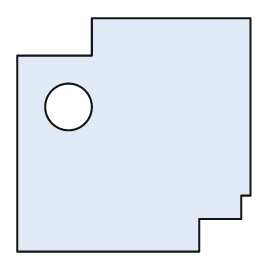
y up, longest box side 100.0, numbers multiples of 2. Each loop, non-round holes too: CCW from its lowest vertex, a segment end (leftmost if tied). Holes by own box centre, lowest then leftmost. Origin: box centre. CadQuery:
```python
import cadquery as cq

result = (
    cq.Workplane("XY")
    .moveTo(-50.0, -50.0)
    .lineTo(28.0, -50.0)
    .lineTo(28.0, -36.0)
    .lineTo(46.0, -36.0)
    .lineTo(46.0, -26.0)
    .lineTo(50.0, -26.0)
    .lineTo(50.0, 50.0)
    .lineTo(-18.0, 50.0)
    .lineTo(-18.0, 34.0)
    .lineTo(-50.0, 34.0)
    .close()
    .moveTo(-28.0, 12.0)
    .circle(10.0)
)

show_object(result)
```